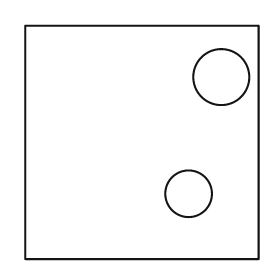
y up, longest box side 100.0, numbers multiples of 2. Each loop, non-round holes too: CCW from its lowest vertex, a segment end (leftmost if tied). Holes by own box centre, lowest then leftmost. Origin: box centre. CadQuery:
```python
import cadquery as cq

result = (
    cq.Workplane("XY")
    .moveTo(-50.0, -50.0)
    .lineTo(50.0, -50.0)
    .lineTo(50.0, 50.0)
    .lineTo(-50.0, 50.0)
    .close()
    .moveTo(20.0, -22.0)
    .circle(10.0)
    .moveTo(34.0, 28.0)
    .circle(12.0)
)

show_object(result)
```